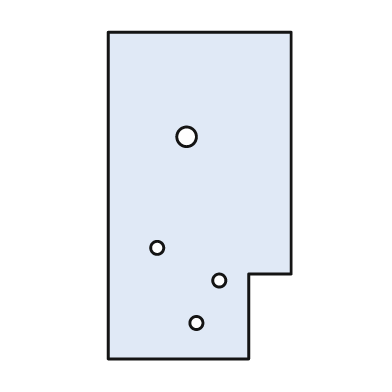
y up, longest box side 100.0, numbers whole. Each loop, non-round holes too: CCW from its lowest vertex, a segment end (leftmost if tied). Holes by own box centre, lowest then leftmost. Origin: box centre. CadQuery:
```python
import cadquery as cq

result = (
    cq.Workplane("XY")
    .moveTo(-28.0, -50.0)
    .lineTo(15.0, -50.0)
    .lineTo(15.0, -24.0)
    .lineTo(28.0, -24.0)
    .lineTo(28.0, 50.0)
    .lineTo(-28.0, 50.0)
    .close()
    .moveTo(-1.0, -39.0)
    .circle(2.0)
    .moveTo(6.0, -26.0)
    .circle(2.0)
    .moveTo(-13.0, -16.0)
    .circle(2.0)
    .moveTo(-4.0, 18.0)
    .circle(3.0)
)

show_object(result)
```